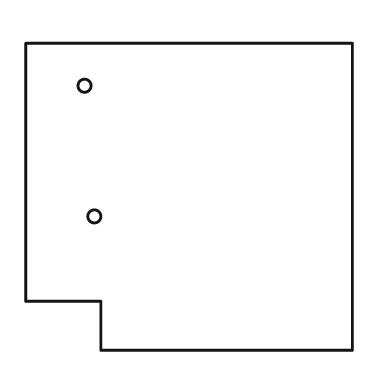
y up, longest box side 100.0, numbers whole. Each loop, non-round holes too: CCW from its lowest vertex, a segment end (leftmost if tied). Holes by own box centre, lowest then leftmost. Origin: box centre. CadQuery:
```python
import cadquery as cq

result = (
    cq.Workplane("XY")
    .moveTo(-27.0, -47.0)
    .lineTo(50.0, -47.0)
    .lineTo(50.0, 47.0)
    .lineTo(-50.0, 47.0)
    .lineTo(-50.0, -32.0)
    .lineTo(-27.0, -32.0)
    .close()
    .moveTo(-29.0, -6.0)
    .circle(2.0)
    .moveTo(-32.0, 34.0)
    .circle(2.0)
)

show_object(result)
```